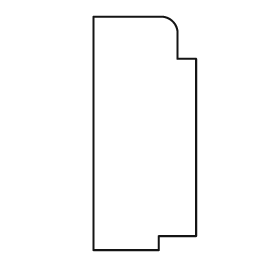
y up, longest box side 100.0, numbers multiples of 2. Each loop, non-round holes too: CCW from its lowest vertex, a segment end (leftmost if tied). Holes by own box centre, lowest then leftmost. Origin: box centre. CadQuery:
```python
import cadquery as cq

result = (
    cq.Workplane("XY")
    .moveTo(-22.0, -50.0)
    .lineTo(6.0, -50.0)
    .lineTo(6.0, -44.0)
    .lineTo(22.0, -44.0)
    .lineTo(22.0, 32.0)
    .lineTo(14.0, 32.0)
    .lineTo(14.0, 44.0)
    .threePointArc((12.0, 48.0), (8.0, 50.0))
    .lineTo(-22.0, 50.0)
    .close()
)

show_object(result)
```